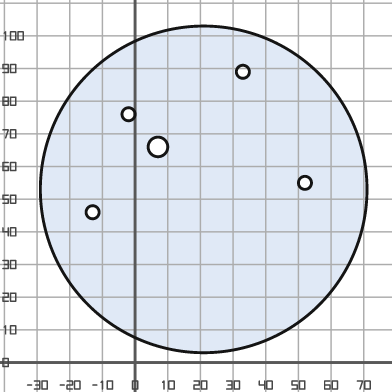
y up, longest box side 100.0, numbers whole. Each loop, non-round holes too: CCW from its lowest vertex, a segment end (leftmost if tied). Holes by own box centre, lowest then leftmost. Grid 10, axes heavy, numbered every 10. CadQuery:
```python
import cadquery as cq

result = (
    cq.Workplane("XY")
    .moveTo(21.0, 53.0)
    .circle(50.0)
    .moveTo(-13.0, 46.0)
    .circle(2.0)
    .moveTo(52.0, 55.0)
    .circle(2.0)
    .moveTo(7.0, 66.0)
    .circle(3.0)
    .moveTo(-2.0, 76.0)
    .circle(2.0)
    .moveTo(33.0, 89.0)
    .circle(2.0)
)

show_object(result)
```